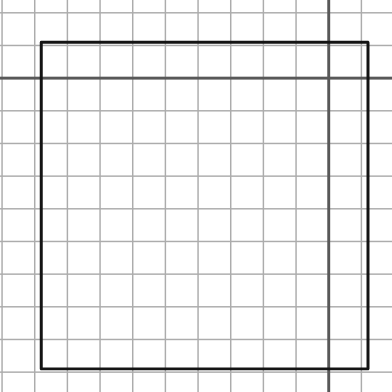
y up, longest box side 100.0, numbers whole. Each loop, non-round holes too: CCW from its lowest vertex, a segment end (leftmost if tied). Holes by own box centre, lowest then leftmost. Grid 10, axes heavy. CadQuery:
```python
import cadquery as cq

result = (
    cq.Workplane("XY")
    .moveTo(-88.0, -89.0)
    .lineTo(12.0, -89.0)
    .lineTo(12.0, 11.0)
    .lineTo(-88.0, 11.0)
    .close()
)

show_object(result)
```